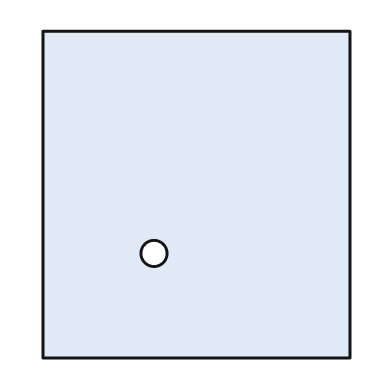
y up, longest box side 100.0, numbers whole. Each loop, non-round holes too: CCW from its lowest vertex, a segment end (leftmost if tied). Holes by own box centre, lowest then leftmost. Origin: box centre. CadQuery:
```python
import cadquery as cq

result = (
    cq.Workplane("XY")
    .moveTo(-47.0, -50.0)
    .lineTo(47.0, -50.0)
    .lineTo(47.0, 50.0)
    .lineTo(-47.0, 50.0)
    .close()
    .moveTo(-13.0, -18.0)
    .circle(4.0)
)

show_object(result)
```